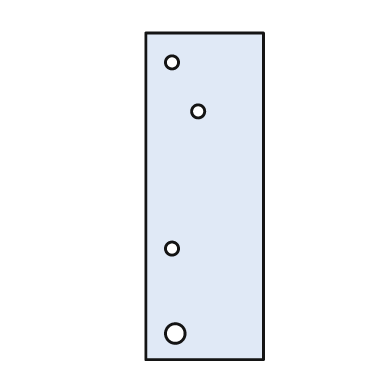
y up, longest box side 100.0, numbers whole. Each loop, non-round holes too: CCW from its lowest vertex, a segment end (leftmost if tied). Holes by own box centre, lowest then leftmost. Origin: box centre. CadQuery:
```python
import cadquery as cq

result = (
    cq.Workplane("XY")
    .moveTo(-18.0, -50.0)
    .lineTo(18.0, -50.0)
    .lineTo(18.0, 50.0)
    .lineTo(-18.0, 50.0)
    .close()
    .moveTo(-9.0, -42.0)
    .circle(3.0)
    .moveTo(-10.0, -16.0)
    .circle(2.0)
    .moveTo(-2.0, 26.0)
    .circle(2.0)
    .moveTo(-10.0, 41.0)
    .circle(2.0)
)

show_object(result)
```